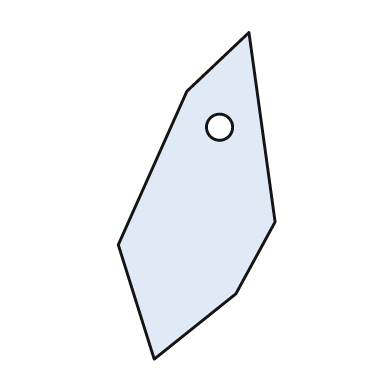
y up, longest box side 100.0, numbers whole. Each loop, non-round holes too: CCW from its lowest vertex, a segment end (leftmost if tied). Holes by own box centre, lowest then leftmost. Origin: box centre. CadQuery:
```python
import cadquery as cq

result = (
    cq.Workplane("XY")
    .moveTo(-13.0, -50.0)
    .lineTo(12.0, -30.0)
    .lineTo(24.0, -8.0)
    .lineTo(16.0, 50.0)
    .lineTo(-3.0, 32.0)
    .lineTo(-24.0, -15.0)
    .close()
    .moveTo(7.0, 21.0)
    .circle(4.0)
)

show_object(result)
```